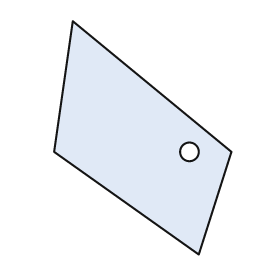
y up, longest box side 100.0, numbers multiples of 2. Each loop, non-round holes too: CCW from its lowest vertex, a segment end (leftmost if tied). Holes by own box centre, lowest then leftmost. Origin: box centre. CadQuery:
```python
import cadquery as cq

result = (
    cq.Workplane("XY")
    .moveTo(24.0, -50.0)
    .lineTo(38.0, -6.0)
    .lineTo(-30.0, 50.0)
    .lineTo(-38.0, -6.0)
    .close()
    .moveTo(20.0, -6.0)
    .circle(4.0)
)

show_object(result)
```